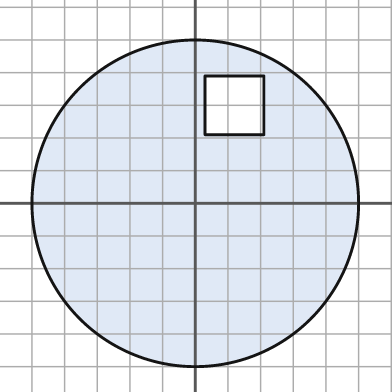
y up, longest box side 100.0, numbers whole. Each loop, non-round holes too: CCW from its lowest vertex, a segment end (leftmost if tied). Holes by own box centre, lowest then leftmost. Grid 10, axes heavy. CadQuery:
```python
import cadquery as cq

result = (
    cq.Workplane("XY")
    .moveTo(0.0, 0.0)
    .circle(50.0)
    .moveTo(3.0, 21.0)
    .lineTo(21.0, 21.0)
    .lineTo(21.0, 39.0)
    .lineTo(3.0, 39.0)
    .close()
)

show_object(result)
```